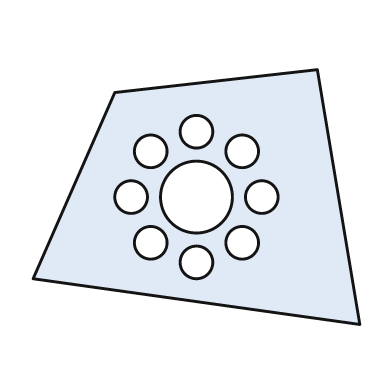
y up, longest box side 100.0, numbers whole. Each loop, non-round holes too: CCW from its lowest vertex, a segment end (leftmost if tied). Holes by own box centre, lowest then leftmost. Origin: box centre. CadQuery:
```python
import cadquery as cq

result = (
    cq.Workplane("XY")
    .moveTo(50.0, -39.0)
    .lineTo(37.0, 39.0)
    .lineTo(-25.0, 32.0)
    .lineTo(-50.0, -25.0)
    .close()
    .moveTo(0.0, -20.0)
    .circle(5.0)
    .moveTo(-14.0, -14.0)
    .circle(5.0)
    .moveTo(14.0, -14.0)
    .circle(5.0)
    .moveTo(-20.0, 0.0)
    .circle(5.0)
    .moveTo(0.0, 0.0)
    .circle(11.0)
    .moveTo(20.0, 0.0)
    .circle(5.0)
    .moveTo(-14.0, 14.0)
    .circle(5.0)
    .moveTo(14.0, 14.0)
    .circle(5.0)
    .moveTo(0.0, 20.0)
    .circle(5.0)
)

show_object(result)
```